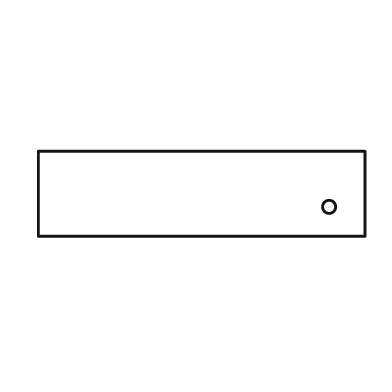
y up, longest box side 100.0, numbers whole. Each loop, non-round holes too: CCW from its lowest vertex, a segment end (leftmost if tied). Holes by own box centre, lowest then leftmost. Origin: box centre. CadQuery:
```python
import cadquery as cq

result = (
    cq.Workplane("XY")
    .moveTo(-50.0, -13.0)
    .lineTo(50.0, -13.0)
    .lineTo(50.0, 13.0)
    .lineTo(-50.0, 13.0)
    .close()
    .moveTo(39.0, -4.0)
    .circle(2.0)
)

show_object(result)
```